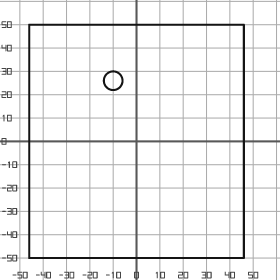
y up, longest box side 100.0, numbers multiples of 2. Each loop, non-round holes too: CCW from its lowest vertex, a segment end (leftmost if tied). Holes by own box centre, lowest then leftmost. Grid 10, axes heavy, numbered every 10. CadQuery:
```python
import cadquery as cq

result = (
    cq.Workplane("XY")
    .moveTo(-46.0, -50.0)
    .lineTo(46.0, -50.0)
    .lineTo(46.0, 50.0)
    .lineTo(-46.0, 50.0)
    .close()
    .moveTo(-10.0, 26.0)
    .circle(4.0)
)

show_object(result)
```